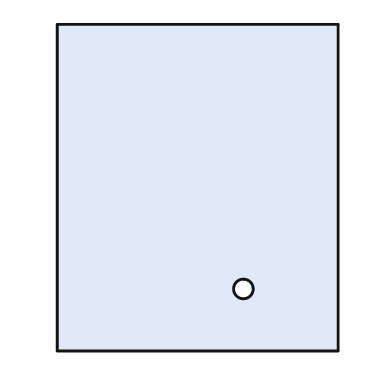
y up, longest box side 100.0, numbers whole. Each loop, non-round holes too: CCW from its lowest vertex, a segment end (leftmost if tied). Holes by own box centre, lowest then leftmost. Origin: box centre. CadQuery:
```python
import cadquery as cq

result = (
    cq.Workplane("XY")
    .moveTo(-43.0, -50.0)
    .lineTo(43.0, -50.0)
    .lineTo(43.0, 50.0)
    .lineTo(-43.0, 50.0)
    .close()
    .moveTo(14.0, -31.0)
    .circle(3.0)
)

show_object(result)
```